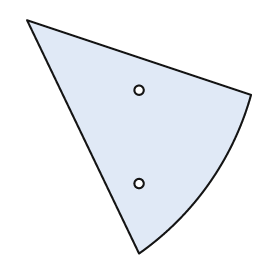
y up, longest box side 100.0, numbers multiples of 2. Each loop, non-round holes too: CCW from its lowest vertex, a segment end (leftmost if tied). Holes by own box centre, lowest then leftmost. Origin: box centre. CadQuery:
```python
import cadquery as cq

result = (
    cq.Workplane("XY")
    .moveTo(0.0, -50.0)
    .threePointArc((30.0, -20.0), (48.0, 18.0))
    .lineTo(-48.0, 50.0)
    .close()
    .moveTo(0.0, -20.0)
    .circle(2.0)
    .moveTo(0.0, 20.0)
    .circle(2.0)
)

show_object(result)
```